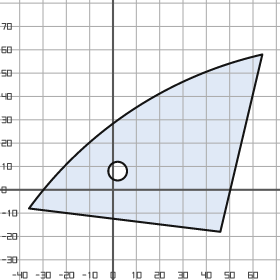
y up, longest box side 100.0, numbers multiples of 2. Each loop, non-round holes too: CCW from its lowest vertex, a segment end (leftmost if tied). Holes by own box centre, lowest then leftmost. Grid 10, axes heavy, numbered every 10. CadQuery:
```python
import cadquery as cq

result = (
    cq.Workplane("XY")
    .moveTo(46.0, -18.0)
    .lineTo(64.0, 58.0)
    .threePointArc((8.0, 34.0), (-36.0, -8.0))
    .close()
    .moveTo(2.0, 8.0)
    .circle(4.0)
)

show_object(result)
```